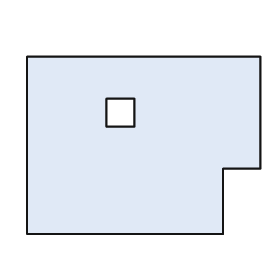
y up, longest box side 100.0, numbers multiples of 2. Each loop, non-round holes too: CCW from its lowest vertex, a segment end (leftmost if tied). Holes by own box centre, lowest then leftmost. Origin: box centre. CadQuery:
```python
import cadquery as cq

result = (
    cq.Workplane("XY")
    .moveTo(-50.0, -38.0)
    .lineTo(34.0, -38.0)
    .lineTo(34.0, -10.0)
    .lineTo(50.0, -10.0)
    .lineTo(50.0, 38.0)
    .lineTo(-50.0, 38.0)
    .close()
    .moveTo(-16.0, 8.0)
    .lineTo(-4.0, 8.0)
    .lineTo(-4.0, 20.0)
    .lineTo(-16.0, 20.0)
    .close()
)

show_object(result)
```